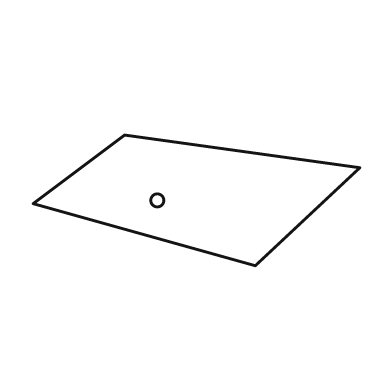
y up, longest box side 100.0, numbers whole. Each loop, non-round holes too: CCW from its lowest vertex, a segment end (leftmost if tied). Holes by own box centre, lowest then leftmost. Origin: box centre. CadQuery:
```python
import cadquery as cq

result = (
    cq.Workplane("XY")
    .moveTo(18.0, -20.0)
    .lineTo(50.0, 10.0)
    .lineTo(-22.0, 20.0)
    .lineTo(-50.0, -1.0)
    .close()
    .moveTo(-12.0, 0.0)
    .circle(2.0)
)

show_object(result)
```